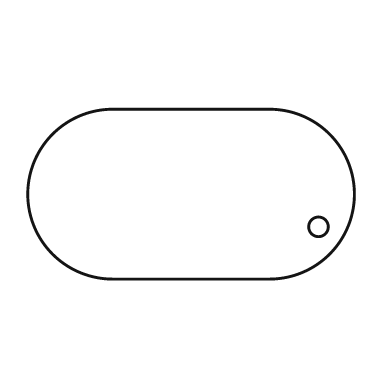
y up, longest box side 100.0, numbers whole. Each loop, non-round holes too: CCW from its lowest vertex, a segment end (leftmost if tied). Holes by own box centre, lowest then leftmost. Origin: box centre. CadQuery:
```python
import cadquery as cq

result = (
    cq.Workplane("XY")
    .moveTo(-24.0, -26.0)
    .lineTo(24.0, -26.0)
    .threePointArc((50.0, 0.0), (24.0, 26.0))
    .lineTo(-24.0, 26.0)
    .threePointArc((-50.0, 0.0), (-24.0, -26.0))
    .close()
    .moveTo(39.0, -10.0)
    .circle(3.0)
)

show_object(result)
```